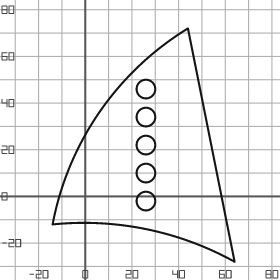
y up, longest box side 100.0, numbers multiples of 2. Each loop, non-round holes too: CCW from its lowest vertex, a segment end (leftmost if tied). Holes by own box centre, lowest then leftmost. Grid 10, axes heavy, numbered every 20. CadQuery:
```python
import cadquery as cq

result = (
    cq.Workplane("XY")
    .moveTo(64.0, -28.0)
    .lineTo(44.0, 72.0)
    .threePointArc((6.0, 36.0), (-14.0, -12.0))
    .threePointArc((26.0, -14.0), (64.0, -28.0))
    .close()
    .moveTo(26.0, -2.0)
    .circle(4.0)
    .moveTo(26.0, 10.0)
    .circle(4.0)
    .moveTo(26.0, 22.0)
    .circle(4.0)
    .moveTo(26.0, 34.0)
    .circle(4.0)
    .moveTo(26.0, 46.0)
    .circle(4.0)
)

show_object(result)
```